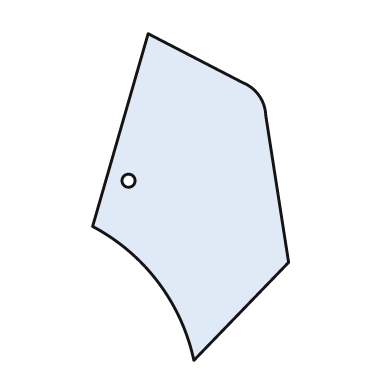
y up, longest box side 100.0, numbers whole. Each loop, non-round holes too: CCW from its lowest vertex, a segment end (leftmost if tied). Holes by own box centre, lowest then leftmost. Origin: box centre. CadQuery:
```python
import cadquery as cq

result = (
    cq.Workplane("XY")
    .moveTo(1.0, -50.0)
    .lineTo(30.0, -20.0)
    .lineTo(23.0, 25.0)
    .threePointArc((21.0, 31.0), (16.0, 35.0))
    .lineTo(-13.0, 50.0)
    .lineTo(-30.0, -9.0)
    .threePointArc((-10.0, -26.0), (1.0, -50.0))
    .close()
    .moveTo(-19.0, 5.0)
    .circle(2.0)
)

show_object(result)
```